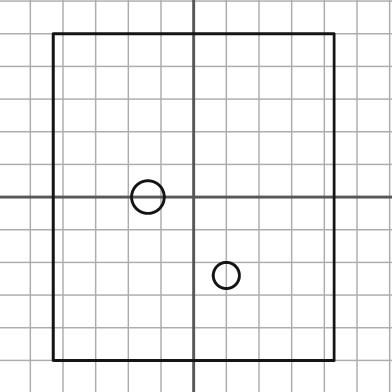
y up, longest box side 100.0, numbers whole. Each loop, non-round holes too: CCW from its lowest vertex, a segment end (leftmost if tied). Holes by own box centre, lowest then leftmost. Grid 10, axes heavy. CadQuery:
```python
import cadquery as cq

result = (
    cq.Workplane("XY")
    .moveTo(-43.0, -50.0)
    .lineTo(43.0, -50.0)
    .lineTo(43.0, 50.0)
    .lineTo(-43.0, 50.0)
    .close()
    .moveTo(10.0, -24.0)
    .circle(4.0)
    .moveTo(-14.0, 0.0)
    .circle(5.0)
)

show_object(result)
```